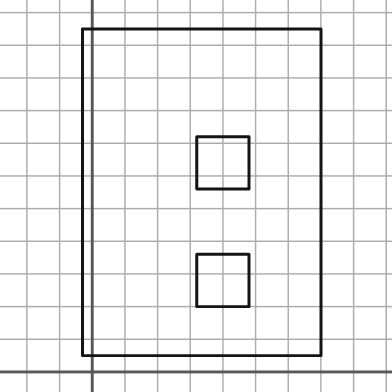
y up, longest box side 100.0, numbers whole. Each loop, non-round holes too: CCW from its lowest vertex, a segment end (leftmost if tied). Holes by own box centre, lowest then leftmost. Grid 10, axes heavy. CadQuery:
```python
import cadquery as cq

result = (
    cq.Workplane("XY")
    .moveTo(-3.0, 5.0)
    .lineTo(70.0, 5.0)
    .lineTo(70.0, 105.0)
    .lineTo(-3.0, 105.0)
    .close()
    .moveTo(32.0, 20.0)
    .lineTo(48.0, 20.0)
    .lineTo(48.0, 36.0)
    .lineTo(32.0, 36.0)
    .close()
    .moveTo(32.0, 56.0)
    .lineTo(48.0, 56.0)
    .lineTo(48.0, 72.0)
    .lineTo(32.0, 72.0)
    .close()
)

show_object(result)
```